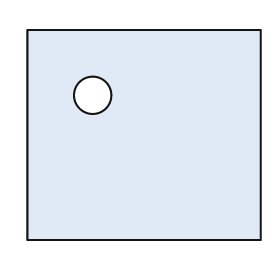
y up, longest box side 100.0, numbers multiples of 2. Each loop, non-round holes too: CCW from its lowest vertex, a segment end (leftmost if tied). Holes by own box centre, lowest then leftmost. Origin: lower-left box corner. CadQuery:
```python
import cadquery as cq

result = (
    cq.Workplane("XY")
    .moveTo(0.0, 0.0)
    .lineTo(100.0, 0.0)
    .lineTo(100.0, 90.0)
    .lineTo(0.0, 90.0)
    .close()
    .moveTo(28.0, 62.0)
    .circle(8.0)
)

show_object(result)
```